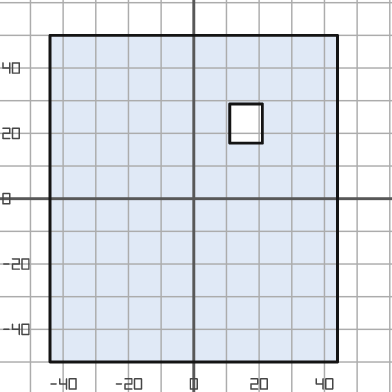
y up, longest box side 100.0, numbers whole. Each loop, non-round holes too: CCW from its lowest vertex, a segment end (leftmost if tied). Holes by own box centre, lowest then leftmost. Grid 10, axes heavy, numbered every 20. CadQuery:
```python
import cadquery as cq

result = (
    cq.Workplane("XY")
    .moveTo(-44.0, -50.0)
    .lineTo(44.0, -50.0)
    .lineTo(44.0, 50.0)
    .lineTo(-44.0, 50.0)
    .close()
    .moveTo(11.0, 17.0)
    .lineTo(21.0, 17.0)
    .lineTo(21.0, 29.0)
    .lineTo(11.0, 29.0)
    .close()
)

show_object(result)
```